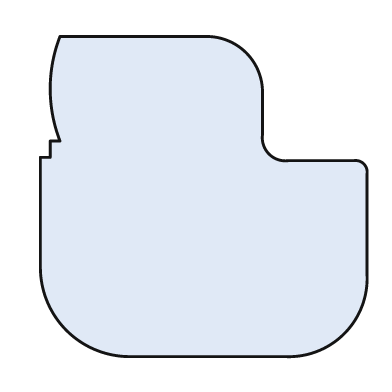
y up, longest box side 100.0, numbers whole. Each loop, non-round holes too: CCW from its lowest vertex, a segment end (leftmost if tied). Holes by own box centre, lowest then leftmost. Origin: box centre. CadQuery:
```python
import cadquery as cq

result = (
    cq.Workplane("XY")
    .moveTo(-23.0, -49.0)
    .lineTo(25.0, -49.0)
    .threePointArc((43.0, -42.0), (50.0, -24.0))
    .lineTo(50.0, 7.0)
    .threePointArc((49.0, 10.0), (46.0, 11.0))
    .lineTo(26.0, 11.0)
    .threePointArc((20.0, 13.0), (18.0, 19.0))
    .lineTo(18.0, 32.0)
    .threePointArc((13.0, 44.0), (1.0, 49.0))
    .lineTo(-44.0, 49.0)
    .threePointArc((-47.0, 33.0), (-44.0, 17.0))
    .lineTo(-47.0, 17.0)
    .lineTo(-47.0, 12.0)
    .lineTo(-50.0, 12.0)
    .lineTo(-50.0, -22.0)
    .threePointArc((-42.0, -41.0), (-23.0, -49.0))
    .close()
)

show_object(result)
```